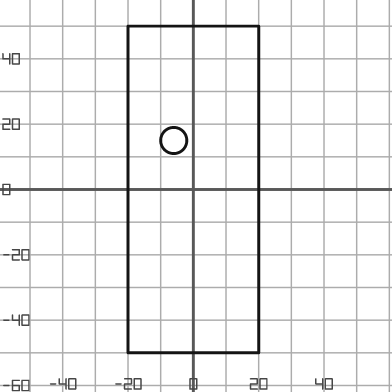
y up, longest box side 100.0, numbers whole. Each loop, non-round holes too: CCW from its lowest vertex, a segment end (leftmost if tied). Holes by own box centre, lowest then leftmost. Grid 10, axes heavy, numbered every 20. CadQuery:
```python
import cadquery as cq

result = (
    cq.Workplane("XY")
    .moveTo(-20.0, -50.0)
    .lineTo(20.0, -50.0)
    .lineTo(20.0, 50.0)
    .lineTo(-20.0, 50.0)
    .close()
    .moveTo(-6.0, 15.0)
    .circle(4.0)
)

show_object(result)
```